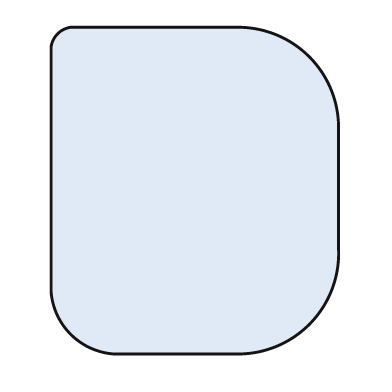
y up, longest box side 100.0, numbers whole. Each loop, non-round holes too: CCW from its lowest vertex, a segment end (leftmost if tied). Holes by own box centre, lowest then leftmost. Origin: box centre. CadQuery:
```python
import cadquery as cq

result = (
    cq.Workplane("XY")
    .moveTo(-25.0, -50.0)
    .lineTo(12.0, -50.0)
    .threePointArc((35.0, -41.0), (44.0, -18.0))
    .lineTo(44.0, 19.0)
    .threePointArc((35.0, 41.0), (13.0, 50.0))
    .lineTo(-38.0, 50.0)
    .threePointArc((-42.0, 48.0), (-44.0, 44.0))
    .lineTo(-44.0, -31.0)
    .threePointArc((-38.0, -44.0), (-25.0, -50.0))
    .close()
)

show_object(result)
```